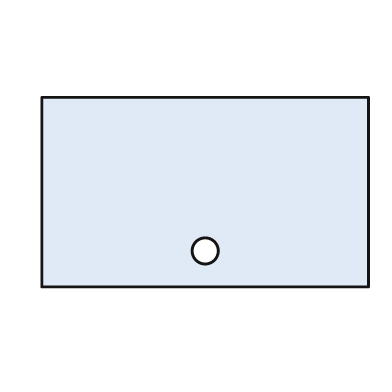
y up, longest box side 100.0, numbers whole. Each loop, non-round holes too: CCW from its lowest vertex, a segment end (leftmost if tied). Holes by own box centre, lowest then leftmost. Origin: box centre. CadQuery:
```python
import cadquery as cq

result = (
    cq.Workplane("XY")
    .moveTo(-50.0, -29.0)
    .lineTo(50.0, -29.0)
    .lineTo(50.0, 29.0)
    .lineTo(-50.0, 29.0)
    .close()
    .moveTo(0.0, -18.0)
    .circle(4.0)
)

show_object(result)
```